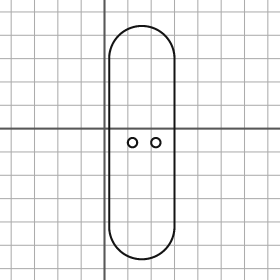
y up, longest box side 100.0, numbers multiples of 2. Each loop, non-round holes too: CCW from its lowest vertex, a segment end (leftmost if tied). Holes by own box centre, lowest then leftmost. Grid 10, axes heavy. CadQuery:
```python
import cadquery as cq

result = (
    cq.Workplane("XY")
    .moveTo(2.0, -42.0)
    .threePointArc((16.0, -56.0), (30.0, -42.0))
    .lineTo(30.0, 30.0)
    .threePointArc((16.0, 44.0), (2.0, 30.0))
    .close()
    .moveTo(12.0, -6.0)
    .circle(2.0)
    .moveTo(22.0, -6.0)
    .circle(2.0)
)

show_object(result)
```